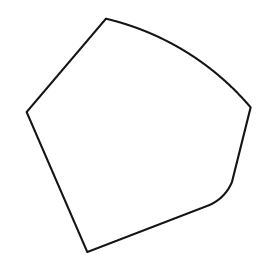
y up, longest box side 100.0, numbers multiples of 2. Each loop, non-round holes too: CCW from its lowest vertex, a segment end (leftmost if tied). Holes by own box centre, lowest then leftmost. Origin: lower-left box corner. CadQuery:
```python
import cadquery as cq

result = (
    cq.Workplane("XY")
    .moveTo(26.0, 0.0)
    .lineTo(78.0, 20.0)
    .threePointArc((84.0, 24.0), (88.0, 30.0))
    .lineTo(96.0, 62.0)
    .threePointArc((68.0, 86.0), (34.0, 100.0))
    .lineTo(0.0, 60.0)
    .close()
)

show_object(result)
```